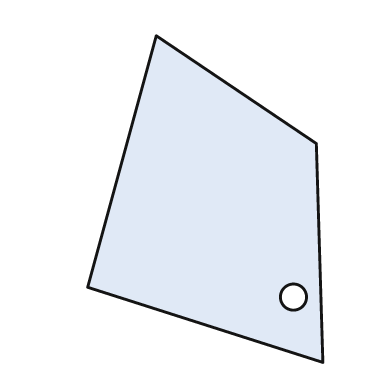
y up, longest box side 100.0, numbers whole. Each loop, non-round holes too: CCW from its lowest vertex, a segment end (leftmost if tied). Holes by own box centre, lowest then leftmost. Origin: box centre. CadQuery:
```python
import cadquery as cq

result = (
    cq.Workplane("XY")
    .moveTo(36.0, -50.0)
    .lineTo(34.0, 17.0)
    .lineTo(-15.0, 50.0)
    .lineTo(-36.0, -27.0)
    .close()
    .moveTo(27.0, -30.0)
    .circle(4.0)
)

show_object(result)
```